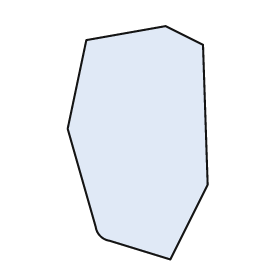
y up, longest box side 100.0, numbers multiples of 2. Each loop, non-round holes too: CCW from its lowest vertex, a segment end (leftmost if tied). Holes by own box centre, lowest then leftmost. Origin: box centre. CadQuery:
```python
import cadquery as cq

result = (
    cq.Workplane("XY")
    .moveTo(14.0, -50.0)
    .lineTo(30.0, -18.0)
    .lineTo(28.0, 42.0)
    .lineTo(12.0, 50.0)
    .lineTo(-22.0, 44.0)
    .lineTo(-30.0, 6.0)
    .lineTo(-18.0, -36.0)
    .threePointArc((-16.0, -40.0), (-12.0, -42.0))
    .close()
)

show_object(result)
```